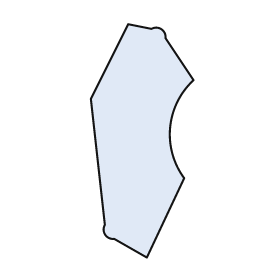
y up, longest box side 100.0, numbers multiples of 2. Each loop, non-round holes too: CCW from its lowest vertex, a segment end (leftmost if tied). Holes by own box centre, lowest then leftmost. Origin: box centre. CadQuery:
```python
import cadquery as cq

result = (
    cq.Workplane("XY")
    .moveTo(2.0, -50.0)
    .lineTo(18.0, -16.0)
    .threePointArc((12.0, 6.0), (22.0, 26.0))
    .lineTo(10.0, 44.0)
    .threePointArc((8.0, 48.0), (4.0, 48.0))
    .lineTo(-6.0, 50.0)
    .lineTo(-22.0, 18.0)
    .lineTo(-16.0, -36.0)
    .threePointArc((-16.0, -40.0), (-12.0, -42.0))
    .close()
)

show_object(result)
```